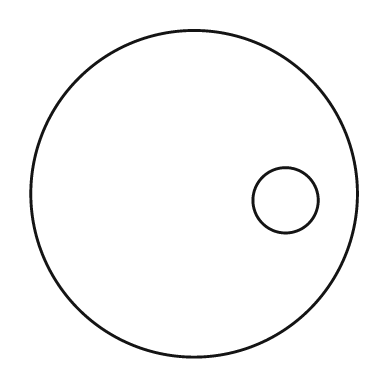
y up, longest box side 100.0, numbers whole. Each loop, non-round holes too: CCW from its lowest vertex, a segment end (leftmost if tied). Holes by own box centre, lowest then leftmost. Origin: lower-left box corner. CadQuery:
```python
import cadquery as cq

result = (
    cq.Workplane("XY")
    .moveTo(50.0, 50.0)
    .circle(50.0)
    .moveTo(78.0, 48.0)
    .circle(10.0)
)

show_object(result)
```